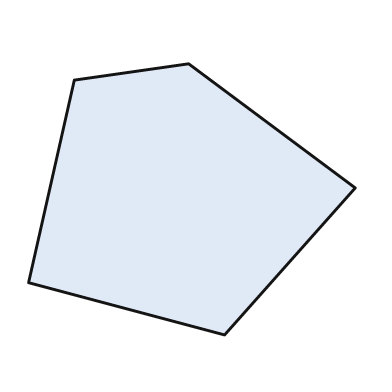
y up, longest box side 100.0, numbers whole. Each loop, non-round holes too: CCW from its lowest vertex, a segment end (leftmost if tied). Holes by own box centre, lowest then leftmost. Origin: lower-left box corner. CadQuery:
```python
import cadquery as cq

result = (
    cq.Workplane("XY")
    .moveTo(60.0, 0.0)
    .lineTo(100.0, 45.0)
    .lineTo(49.0, 83.0)
    .lineTo(14.0, 78.0)
    .lineTo(0.0, 16.0)
    .close()
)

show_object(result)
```